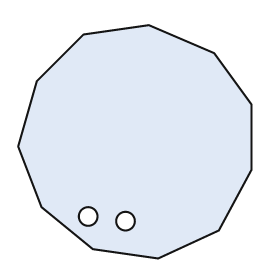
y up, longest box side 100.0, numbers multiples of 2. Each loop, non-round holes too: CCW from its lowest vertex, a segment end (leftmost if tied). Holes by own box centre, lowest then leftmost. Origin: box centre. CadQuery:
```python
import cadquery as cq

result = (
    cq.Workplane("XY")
    .moveTo(10.0, -50.0)
    .lineTo(36.0, -38.0)
    .lineTo(50.0, -12.0)
    .lineTo(50.0, 16.0)
    .lineTo(34.0, 38.0)
    .lineTo(6.0, 50.0)
    .lineTo(-22.0, 46.0)
    .lineTo(-42.0, 26.0)
    .lineTo(-50.0, -2.0)
    .lineTo(-40.0, -28.0)
    .lineTo(-18.0, -46.0)
    .close()
    .moveTo(-4.0, -34.0)
    .circle(4.0)
    .moveTo(-20.0, -32.0)
    .circle(4.0)
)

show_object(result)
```